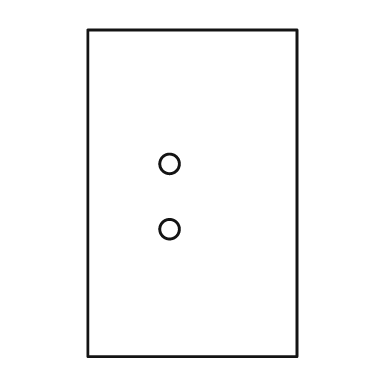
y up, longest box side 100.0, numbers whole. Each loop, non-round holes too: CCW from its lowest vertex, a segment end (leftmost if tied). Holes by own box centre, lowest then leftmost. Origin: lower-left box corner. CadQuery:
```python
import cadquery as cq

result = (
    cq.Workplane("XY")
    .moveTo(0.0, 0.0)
    .lineTo(64.0, 0.0)
    .lineTo(64.0, 100.0)
    .lineTo(0.0, 100.0)
    .close()
    .moveTo(25.0, 39.0)
    .circle(3.0)
    .moveTo(25.0, 59.0)
    .circle(3.0)
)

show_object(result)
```